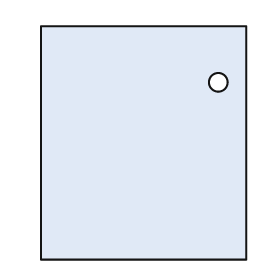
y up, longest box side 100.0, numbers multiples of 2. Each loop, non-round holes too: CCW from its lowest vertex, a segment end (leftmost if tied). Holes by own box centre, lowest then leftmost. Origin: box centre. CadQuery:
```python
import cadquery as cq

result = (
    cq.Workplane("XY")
    .moveTo(-44.0, -50.0)
    .lineTo(44.0, -50.0)
    .lineTo(44.0, 50.0)
    .lineTo(-44.0, 50.0)
    .close()
    .moveTo(32.0, 26.0)
    .circle(4.0)
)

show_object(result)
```